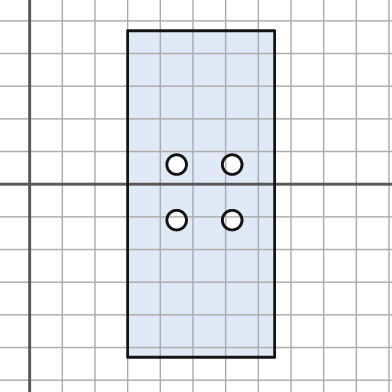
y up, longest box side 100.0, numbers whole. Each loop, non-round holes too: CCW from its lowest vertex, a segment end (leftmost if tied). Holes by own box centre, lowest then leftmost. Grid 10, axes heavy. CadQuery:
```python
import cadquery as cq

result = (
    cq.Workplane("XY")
    .moveTo(30.0, -53.0)
    .lineTo(75.0, -53.0)
    .lineTo(75.0, 47.0)
    .lineTo(30.0, 47.0)
    .close()
    .moveTo(45.0, -11.0)
    .circle(3.0)
    .moveTo(62.0, -11.0)
    .circle(3.0)
    .moveTo(45.0, 6.0)
    .circle(3.0)
    .moveTo(62.0, 6.0)
    .circle(3.0)
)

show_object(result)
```